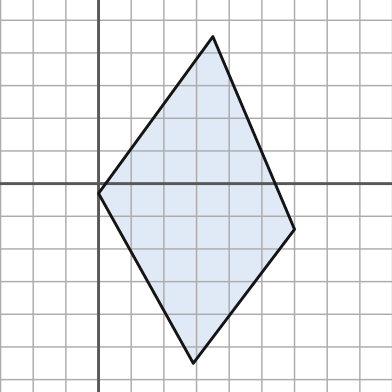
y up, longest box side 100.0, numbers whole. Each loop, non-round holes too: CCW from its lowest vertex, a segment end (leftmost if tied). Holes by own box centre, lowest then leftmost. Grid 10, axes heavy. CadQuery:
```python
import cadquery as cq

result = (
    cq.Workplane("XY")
    .moveTo(29.0, -55.0)
    .lineTo(60.0, -14.0)
    .lineTo(35.0, 45.0)
    .lineTo(0.0, -3.0)
    .close()
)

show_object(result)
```